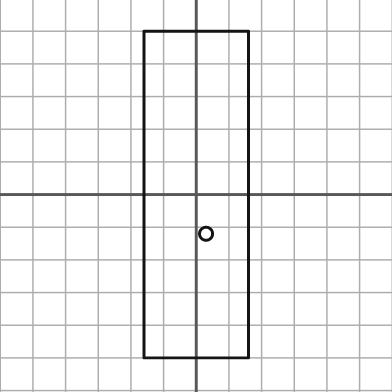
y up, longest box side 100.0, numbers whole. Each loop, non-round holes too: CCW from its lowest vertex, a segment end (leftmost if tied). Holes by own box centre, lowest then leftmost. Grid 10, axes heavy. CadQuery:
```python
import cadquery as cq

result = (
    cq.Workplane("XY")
    .moveTo(-16.0, -50.0)
    .lineTo(16.0, -50.0)
    .lineTo(16.0, 50.0)
    .lineTo(-16.0, 50.0)
    .close()
    .moveTo(3.0, -12.0)
    .circle(2.0)
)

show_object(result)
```